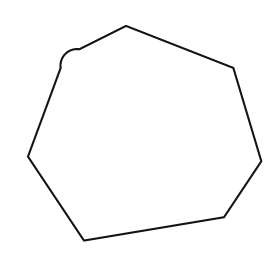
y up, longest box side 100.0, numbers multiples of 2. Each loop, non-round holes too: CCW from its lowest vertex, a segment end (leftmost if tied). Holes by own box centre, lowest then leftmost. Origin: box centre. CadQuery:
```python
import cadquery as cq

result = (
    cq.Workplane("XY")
    .moveTo(-26.0, -46.0)
    .lineTo(34.0, -36.0)
    .lineTo(50.0, -12.0)
    .lineTo(38.0, 28.0)
    .lineTo(-8.0, 46.0)
    .lineTo(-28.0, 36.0)
    .threePointArc((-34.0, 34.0), (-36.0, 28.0))
    .lineTo(-50.0, -10.0)
    .close()
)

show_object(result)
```